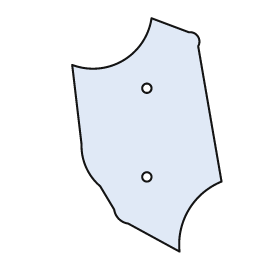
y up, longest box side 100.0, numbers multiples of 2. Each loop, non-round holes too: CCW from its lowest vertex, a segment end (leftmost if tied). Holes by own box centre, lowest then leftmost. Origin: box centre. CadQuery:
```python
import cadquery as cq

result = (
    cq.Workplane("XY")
    .moveTo(14.0, -50.0)
    .threePointArc((18.0, -32.0), (32.0, -20.0))
    .lineTo(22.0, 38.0)
    .threePointArc((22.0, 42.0), (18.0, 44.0))
    .lineTo(2.0, 50.0)
    .threePointArc((-10.0, 32.0), (-32.0, 30.0))
    .lineTo(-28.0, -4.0)
    .threePointArc((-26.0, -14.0), (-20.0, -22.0))
    .lineTo(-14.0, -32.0)
    .threePointArc((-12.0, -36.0), (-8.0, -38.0))
    .close()
    .moveTo(0.0, -18.0)
    .circle(2.0)
    .moveTo(0.0, 20.0)
    .circle(2.0)
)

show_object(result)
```